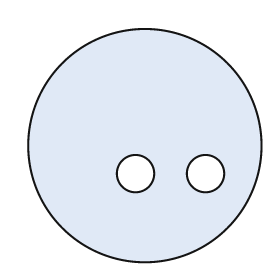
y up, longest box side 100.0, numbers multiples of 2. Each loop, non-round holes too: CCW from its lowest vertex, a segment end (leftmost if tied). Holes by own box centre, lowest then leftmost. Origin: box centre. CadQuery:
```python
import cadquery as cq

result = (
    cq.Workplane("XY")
    .moveTo(0.0, 0.0)
    .circle(50.0)
    .moveTo(-4.0, -12.0)
    .circle(8.0)
    .moveTo(26.0, -12.0)
    .circle(8.0)
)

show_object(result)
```